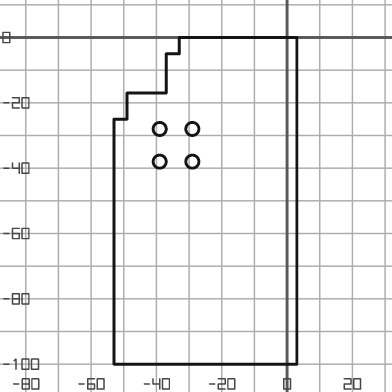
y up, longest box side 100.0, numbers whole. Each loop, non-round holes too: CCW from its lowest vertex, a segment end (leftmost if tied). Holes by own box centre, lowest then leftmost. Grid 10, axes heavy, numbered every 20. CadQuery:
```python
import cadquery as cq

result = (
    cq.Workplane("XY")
    .moveTo(-53.0, -100.0)
    .lineTo(3.0, -100.0)
    .lineTo(3.0, 0.0)
    .lineTo(-33.0, 0.0)
    .lineTo(-33.0, -5.0)
    .lineTo(-37.0, -5.0)
    .lineTo(-37.0, -17.0)
    .lineTo(-49.0, -17.0)
    .lineTo(-49.0, -25.0)
    .lineTo(-53.0, -25.0)
    .close()
    .moveTo(-39.0, -38.0)
    .circle(2.0)
    .moveTo(-29.0, -38.0)
    .circle(2.0)
    .moveTo(-39.0, -28.0)
    .circle(2.0)
    .moveTo(-29.0, -28.0)
    .circle(2.0)
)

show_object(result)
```